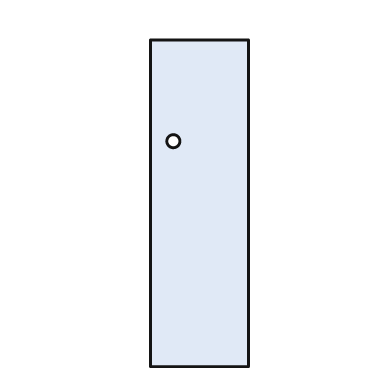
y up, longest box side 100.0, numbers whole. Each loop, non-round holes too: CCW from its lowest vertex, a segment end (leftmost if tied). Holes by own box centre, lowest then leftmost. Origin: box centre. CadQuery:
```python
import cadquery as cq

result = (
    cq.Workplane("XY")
    .moveTo(-15.0, -50.0)
    .lineTo(15.0, -50.0)
    .lineTo(15.0, 50.0)
    .lineTo(-15.0, 50.0)
    .close()
    .moveTo(-8.0, 19.0)
    .circle(2.0)
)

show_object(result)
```